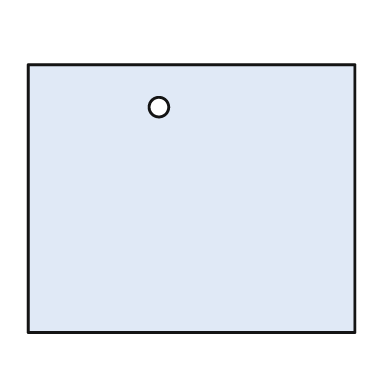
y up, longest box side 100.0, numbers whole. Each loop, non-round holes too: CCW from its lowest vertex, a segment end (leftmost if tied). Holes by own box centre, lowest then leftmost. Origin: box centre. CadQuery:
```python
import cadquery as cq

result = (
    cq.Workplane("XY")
    .moveTo(-50.0, -41.0)
    .lineTo(50.0, -41.0)
    .lineTo(50.0, 41.0)
    .lineTo(-50.0, 41.0)
    .close()
    .moveTo(-10.0, 28.0)
    .circle(3.0)
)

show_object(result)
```